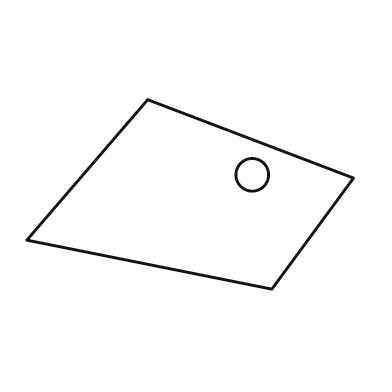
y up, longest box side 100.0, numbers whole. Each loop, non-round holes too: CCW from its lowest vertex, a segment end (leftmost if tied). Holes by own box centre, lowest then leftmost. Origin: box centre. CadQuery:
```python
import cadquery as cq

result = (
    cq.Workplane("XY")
    .moveTo(25.0, -29.0)
    .lineTo(50.0, 5.0)
    .lineTo(-13.0, 29.0)
    .lineTo(-50.0, -14.0)
    .close()
    .moveTo(19.0, 6.0)
    .circle(5.0)
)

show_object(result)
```